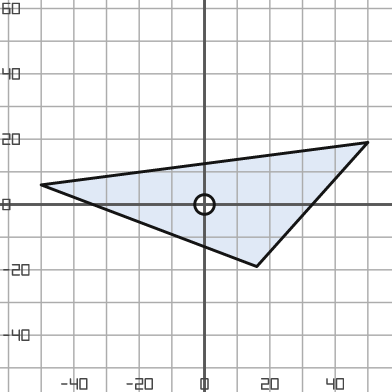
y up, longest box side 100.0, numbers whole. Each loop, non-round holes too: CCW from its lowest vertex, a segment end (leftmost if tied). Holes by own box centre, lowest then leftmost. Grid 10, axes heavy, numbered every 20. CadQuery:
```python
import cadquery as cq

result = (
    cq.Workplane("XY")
    .moveTo(16.0, -19.0)
    .lineTo(50.0, 19.0)
    .lineTo(-50.0, 6.0)
    .close()
    .moveTo(0.0, 0.0)
    .circle(3.0)
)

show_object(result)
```